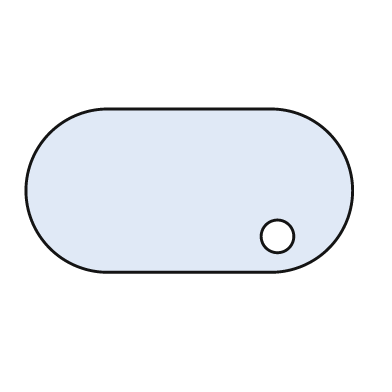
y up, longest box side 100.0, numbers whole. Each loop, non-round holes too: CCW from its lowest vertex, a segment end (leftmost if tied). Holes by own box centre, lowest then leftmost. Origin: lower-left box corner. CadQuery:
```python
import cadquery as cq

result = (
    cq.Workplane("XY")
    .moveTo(25.0, 0.0)
    .lineTo(75.0, 0.0)
    .threePointArc((100.0, 25.0), (75.0, 50.0))
    .lineTo(25.0, 50.0)
    .threePointArc((0.0, 25.0), (25.0, 0.0))
    .close()
    .moveTo(77.0, 11.0)
    .circle(5.0)
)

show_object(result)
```